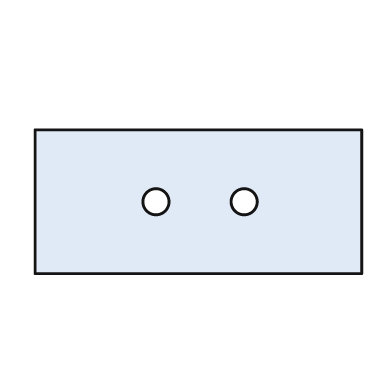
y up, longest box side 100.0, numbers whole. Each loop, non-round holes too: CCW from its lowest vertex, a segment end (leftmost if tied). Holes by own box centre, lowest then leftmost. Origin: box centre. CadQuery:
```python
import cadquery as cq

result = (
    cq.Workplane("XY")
    .moveTo(-50.0, -22.0)
    .lineTo(50.0, -22.0)
    .lineTo(50.0, 22.0)
    .lineTo(-50.0, 22.0)
    .close()
    .moveTo(-13.0, 0.0)
    .circle(4.0)
    .moveTo(14.0, 0.0)
    .circle(4.0)
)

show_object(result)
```